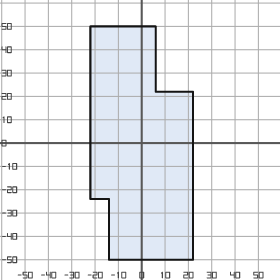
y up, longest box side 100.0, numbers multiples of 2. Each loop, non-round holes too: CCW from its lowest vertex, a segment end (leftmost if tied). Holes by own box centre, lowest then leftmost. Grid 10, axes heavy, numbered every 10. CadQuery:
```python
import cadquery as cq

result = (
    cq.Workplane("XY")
    .moveTo(-14.0, -50.0)
    .lineTo(22.0, -50.0)
    .lineTo(22.0, 22.0)
    .lineTo(6.0, 22.0)
    .lineTo(6.0, 50.0)
    .lineTo(-22.0, 50.0)
    .lineTo(-22.0, -24.0)
    .lineTo(-14.0, -24.0)
    .close()
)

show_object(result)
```